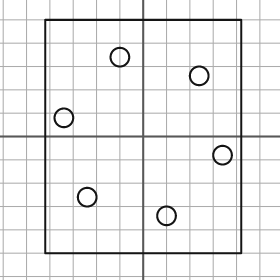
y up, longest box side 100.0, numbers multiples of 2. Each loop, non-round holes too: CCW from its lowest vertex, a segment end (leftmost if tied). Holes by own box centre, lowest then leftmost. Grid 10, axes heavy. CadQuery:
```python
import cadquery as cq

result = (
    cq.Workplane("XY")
    .moveTo(-42.0, -50.0)
    .lineTo(42.0, -50.0)
    .lineTo(42.0, 50.0)
    .lineTo(-42.0, 50.0)
    .close()
    .moveTo(10.0, -34.0)
    .circle(4.0)
    .moveTo(-24.0, -26.0)
    .circle(4.0)
    .moveTo(34.0, -8.0)
    .circle(4.0)
    .moveTo(-34.0, 8.0)
    .circle(4.0)
    .moveTo(24.0, 26.0)
    .circle(4.0)
    .moveTo(-10.0, 34.0)
    .circle(4.0)
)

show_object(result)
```